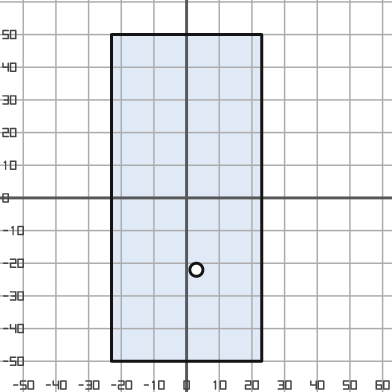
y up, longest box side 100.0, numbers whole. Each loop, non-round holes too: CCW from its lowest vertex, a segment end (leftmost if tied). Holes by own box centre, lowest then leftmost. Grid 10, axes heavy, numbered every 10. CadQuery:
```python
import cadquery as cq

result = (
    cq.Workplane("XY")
    .moveTo(-23.0, -50.0)
    .lineTo(23.0, -50.0)
    .lineTo(23.0, 50.0)
    .lineTo(-23.0, 50.0)
    .close()
    .moveTo(3.0, -22.0)
    .circle(2.0)
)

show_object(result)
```